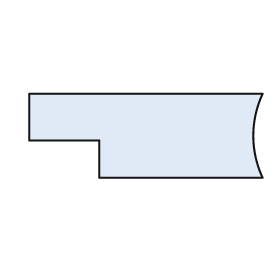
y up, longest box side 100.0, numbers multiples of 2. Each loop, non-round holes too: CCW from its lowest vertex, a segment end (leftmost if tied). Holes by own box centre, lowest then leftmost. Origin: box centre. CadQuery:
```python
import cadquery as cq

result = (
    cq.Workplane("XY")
    .moveTo(-20.0, -18.0)
    .lineTo(50.0, -18.0)
    .threePointArc((46.0, 0.0), (50.0, 18.0))
    .lineTo(-50.0, 18.0)
    .lineTo(-50.0, -2.0)
    .lineTo(-20.0, -2.0)
    .close()
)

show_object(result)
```